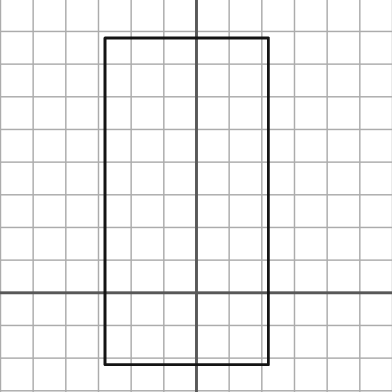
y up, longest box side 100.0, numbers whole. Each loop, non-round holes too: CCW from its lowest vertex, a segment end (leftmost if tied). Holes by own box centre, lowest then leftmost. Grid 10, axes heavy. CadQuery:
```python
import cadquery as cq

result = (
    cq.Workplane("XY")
    .moveTo(-28.0, -22.0)
    .lineTo(22.0, -22.0)
    .lineTo(22.0, 78.0)
    .lineTo(-28.0, 78.0)
    .close()
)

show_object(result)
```